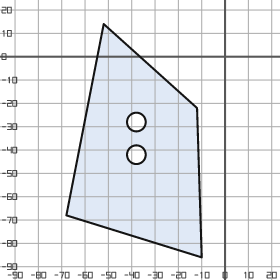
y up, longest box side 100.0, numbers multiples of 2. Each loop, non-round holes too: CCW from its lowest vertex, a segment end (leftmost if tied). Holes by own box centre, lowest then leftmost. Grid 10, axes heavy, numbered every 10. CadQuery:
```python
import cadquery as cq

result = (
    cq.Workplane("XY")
    .moveTo(-10.0, -86.0)
    .lineTo(-12.0, -22.0)
    .lineTo(-52.0, 14.0)
    .lineTo(-68.0, -68.0)
    .close()
    .moveTo(-38.0, -42.0)
    .circle(4.0)
    .moveTo(-38.0, -28.0)
    .circle(4.0)
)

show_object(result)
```